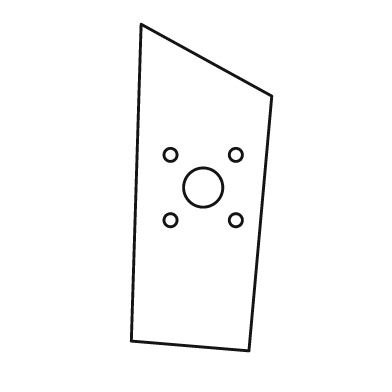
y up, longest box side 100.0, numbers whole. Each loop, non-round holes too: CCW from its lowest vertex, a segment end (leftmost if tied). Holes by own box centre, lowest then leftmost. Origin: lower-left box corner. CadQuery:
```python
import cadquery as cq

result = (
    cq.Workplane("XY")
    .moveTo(36.0, 0.0)
    .lineTo(43.0, 78.0)
    .lineTo(3.0, 100.0)
    .lineTo(0.0, 3.0)
    .close()
    .moveTo(12.0, 40.0)
    .circle(2.0)
    .moveTo(32.0, 40.0)
    .circle(2.0)
    .moveTo(22.0, 50.0)
    .circle(6.0)
    .moveTo(12.0, 60.0)
    .circle(2.0)
    .moveTo(32.0, 60.0)
    .circle(2.0)
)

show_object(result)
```